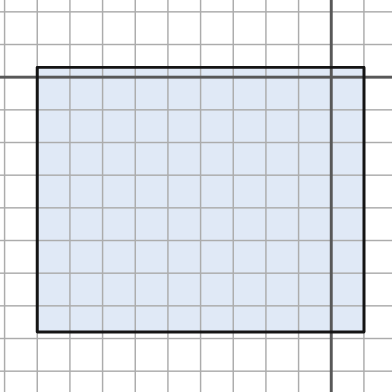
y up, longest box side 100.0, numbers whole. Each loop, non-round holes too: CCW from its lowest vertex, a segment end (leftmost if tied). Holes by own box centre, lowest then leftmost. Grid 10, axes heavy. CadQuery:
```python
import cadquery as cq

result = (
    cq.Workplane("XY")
    .moveTo(-90.0, -78.0)
    .lineTo(10.0, -78.0)
    .lineTo(10.0, 3.0)
    .lineTo(-90.0, 3.0)
    .close()
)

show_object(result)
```